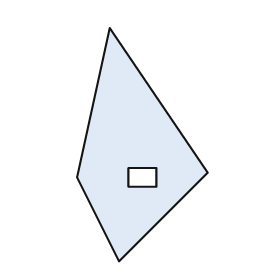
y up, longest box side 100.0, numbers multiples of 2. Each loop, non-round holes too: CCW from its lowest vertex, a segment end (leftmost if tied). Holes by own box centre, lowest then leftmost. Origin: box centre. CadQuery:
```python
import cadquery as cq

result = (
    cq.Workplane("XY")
    .moveTo(-10.0, -50.0)
    .lineTo(28.0, -12.0)
    .lineTo(-14.0, 50.0)
    .lineTo(-28.0, -14.0)
    .close()
    .moveTo(-6.0, -18.0)
    .lineTo(6.0, -18.0)
    .lineTo(6.0, -10.0)
    .lineTo(-6.0, -10.0)
    .close()
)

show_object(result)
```